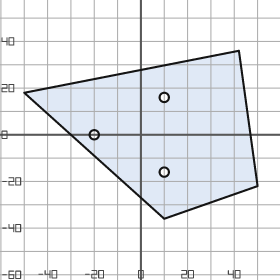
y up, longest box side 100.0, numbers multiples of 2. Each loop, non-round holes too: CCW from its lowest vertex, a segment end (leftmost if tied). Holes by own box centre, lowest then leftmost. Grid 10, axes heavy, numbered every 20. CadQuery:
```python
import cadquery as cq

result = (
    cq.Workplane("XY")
    .moveTo(10.0, -36.0)
    .lineTo(50.0, -22.0)
    .lineTo(42.0, 36.0)
    .lineTo(-50.0, 18.0)
    .close()
    .moveTo(10.0, -16.0)
    .circle(2.0)
    .moveTo(-20.0, 0.0)
    .circle(2.0)
    .moveTo(10.0, 16.0)
    .circle(2.0)
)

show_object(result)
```